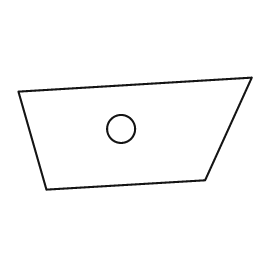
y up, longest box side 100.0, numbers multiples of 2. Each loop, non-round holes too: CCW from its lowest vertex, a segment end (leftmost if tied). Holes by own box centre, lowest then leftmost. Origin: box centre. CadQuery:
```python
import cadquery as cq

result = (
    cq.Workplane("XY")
    .moveTo(-38.0, -24.0)
    .lineTo(30.0, -20.0)
    .lineTo(50.0, 24.0)
    .lineTo(-50.0, 18.0)
    .close()
    .moveTo(-6.0, 2.0)
    .circle(6.0)
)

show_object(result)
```